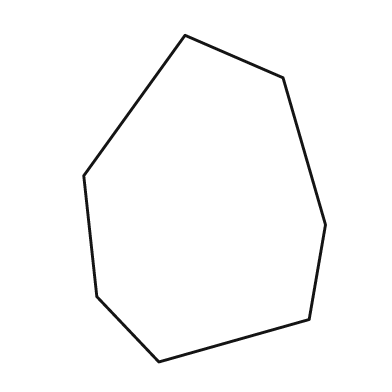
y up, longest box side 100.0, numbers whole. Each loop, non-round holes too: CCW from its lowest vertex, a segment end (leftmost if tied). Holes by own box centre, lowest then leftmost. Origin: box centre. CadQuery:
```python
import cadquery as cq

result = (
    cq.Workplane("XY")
    .moveTo(-14.0, -50.0)
    .lineTo(32.0, -37.0)
    .lineTo(37.0, -8.0)
    .lineTo(24.0, 37.0)
    .lineTo(-6.0, 50.0)
    .lineTo(-37.0, 7.0)
    .lineTo(-33.0, -30.0)
    .close()
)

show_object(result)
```